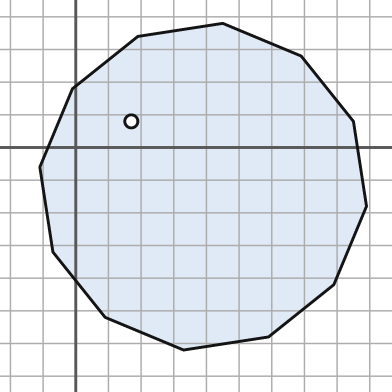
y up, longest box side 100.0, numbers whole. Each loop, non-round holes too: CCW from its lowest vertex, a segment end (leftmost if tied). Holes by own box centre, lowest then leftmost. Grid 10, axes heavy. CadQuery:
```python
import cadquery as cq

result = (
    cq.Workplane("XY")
    .moveTo(33.0, -62.0)
    .lineTo(59.0, -58.0)
    .lineTo(79.0, -42.0)
    .lineTo(89.0, -18.0)
    .lineTo(85.0, 8.0)
    .lineTo(69.0, 28.0)
    .lineTo(45.0, 38.0)
    .lineTo(19.0, 34.0)
    .lineTo(-1.0, 18.0)
    .lineTo(-11.0, -6.0)
    .lineTo(-7.0, -32.0)
    .lineTo(9.0, -52.0)
    .close()
    .moveTo(17.0, 8.0)
    .circle(2.0)
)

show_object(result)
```